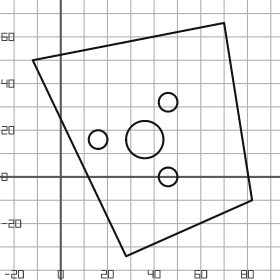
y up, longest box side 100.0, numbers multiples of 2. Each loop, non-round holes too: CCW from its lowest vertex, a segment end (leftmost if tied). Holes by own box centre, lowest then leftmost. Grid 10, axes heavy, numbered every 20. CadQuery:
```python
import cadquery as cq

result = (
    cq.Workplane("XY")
    .moveTo(28.0, -34.0)
    .lineTo(82.0, -10.0)
    .lineTo(70.0, 66.0)
    .lineTo(-12.0, 50.0)
    .close()
    .moveTo(46.0, 0.0)
    .circle(4.0)
    .moveTo(16.0, 16.0)
    .circle(4.0)
    .moveTo(36.0, 16.0)
    .circle(8.0)
    .moveTo(46.0, 32.0)
    .circle(4.0)
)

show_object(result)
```